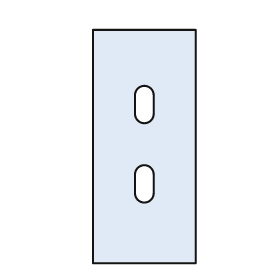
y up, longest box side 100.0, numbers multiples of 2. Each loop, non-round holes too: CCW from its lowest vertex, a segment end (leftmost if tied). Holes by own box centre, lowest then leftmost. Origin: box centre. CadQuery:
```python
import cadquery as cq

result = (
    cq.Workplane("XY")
    .moveTo(-22.0, -50.0)
    .lineTo(22.0, -50.0)
    .lineTo(22.0, 50.0)
    .lineTo(-22.0, 50.0)
    .close()
    .moveTo(-4.0, -20.0)
    .threePointArc((0.0, -24.0), (4.0, -20.0))
    .lineTo(4.0, -12.0)
    .threePointArc((0.0, -8.0), (-4.0, -12.0))
    .close()
    .moveTo(-4.0, 14.0)
    .threePointArc((0.0, 10.0), (4.0, 14.0))
    .lineTo(4.0, 22.0)
    .threePointArc((0.0, 26.0), (-4.0, 22.0))
    .close()
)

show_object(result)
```